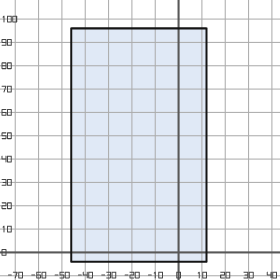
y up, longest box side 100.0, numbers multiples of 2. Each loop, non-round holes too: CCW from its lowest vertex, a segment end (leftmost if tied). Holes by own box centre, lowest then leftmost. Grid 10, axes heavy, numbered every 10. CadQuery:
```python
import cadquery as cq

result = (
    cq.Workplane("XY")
    .moveTo(-46.0, -4.0)
    .lineTo(12.0, -4.0)
    .lineTo(12.0, 96.0)
    .lineTo(-46.0, 96.0)
    .close()
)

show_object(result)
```